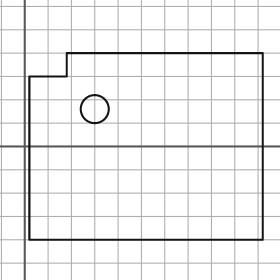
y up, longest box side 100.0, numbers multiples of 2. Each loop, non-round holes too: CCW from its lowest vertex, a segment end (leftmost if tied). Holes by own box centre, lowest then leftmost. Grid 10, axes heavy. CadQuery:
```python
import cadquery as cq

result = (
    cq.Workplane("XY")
    .moveTo(2.0, -40.0)
    .lineTo(102.0, -40.0)
    .lineTo(102.0, 40.0)
    .lineTo(18.0, 40.0)
    .lineTo(18.0, 30.0)
    .lineTo(2.0, 30.0)
    .close()
    .moveTo(30.0, 16.0)
    .circle(6.0)
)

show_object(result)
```